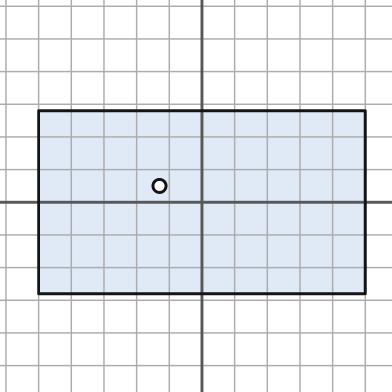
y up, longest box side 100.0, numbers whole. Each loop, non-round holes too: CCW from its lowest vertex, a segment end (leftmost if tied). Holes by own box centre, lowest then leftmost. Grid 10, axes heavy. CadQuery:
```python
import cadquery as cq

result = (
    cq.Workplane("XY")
    .moveTo(-50.0, -28.0)
    .lineTo(50.0, -28.0)
    .lineTo(50.0, 28.0)
    .lineTo(-50.0, 28.0)
    .close()
    .moveTo(-13.0, 5.0)
    .circle(2.0)
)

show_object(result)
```